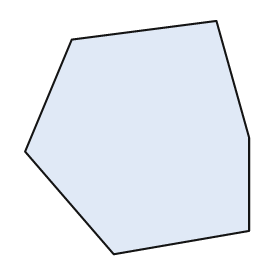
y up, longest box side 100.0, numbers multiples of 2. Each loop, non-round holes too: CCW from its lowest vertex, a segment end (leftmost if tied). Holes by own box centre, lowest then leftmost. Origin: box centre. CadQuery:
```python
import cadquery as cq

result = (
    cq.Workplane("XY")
    .moveTo(-10.0, -50.0)
    .lineTo(48.0, -40.0)
    .lineTo(48.0, 0.0)
    .lineTo(34.0, 50.0)
    .lineTo(-28.0, 42.0)
    .lineTo(-48.0, -6.0)
    .close()
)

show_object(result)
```